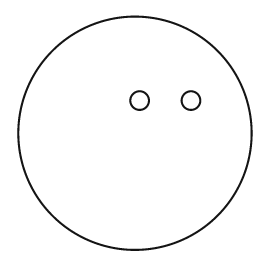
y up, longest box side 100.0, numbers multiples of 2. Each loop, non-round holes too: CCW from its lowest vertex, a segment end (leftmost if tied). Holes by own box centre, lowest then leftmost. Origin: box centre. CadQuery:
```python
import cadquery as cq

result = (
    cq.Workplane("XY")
    .moveTo(0.0, 0.0)
    .circle(50.0)
    .moveTo(2.0, 14.0)
    .circle(4.0)
    .moveTo(24.0, 14.0)
    .circle(4.0)
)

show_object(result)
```